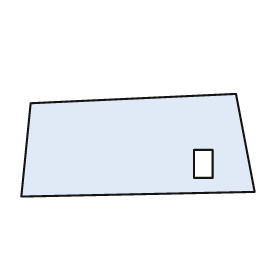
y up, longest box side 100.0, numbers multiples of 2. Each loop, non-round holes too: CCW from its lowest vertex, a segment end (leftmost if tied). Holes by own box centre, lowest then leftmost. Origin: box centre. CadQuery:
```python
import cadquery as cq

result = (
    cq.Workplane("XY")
    .moveTo(-50.0, -22.0)
    .lineTo(50.0, -20.0)
    .lineTo(42.0, 22.0)
    .lineTo(-46.0, 18.0)
    .close()
    .moveTo(24.0, -14.0)
    .lineTo(32.0, -14.0)
    .lineTo(32.0, -2.0)
    .lineTo(24.0, -2.0)
    .close()
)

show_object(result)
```